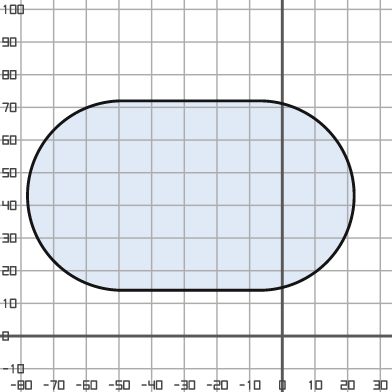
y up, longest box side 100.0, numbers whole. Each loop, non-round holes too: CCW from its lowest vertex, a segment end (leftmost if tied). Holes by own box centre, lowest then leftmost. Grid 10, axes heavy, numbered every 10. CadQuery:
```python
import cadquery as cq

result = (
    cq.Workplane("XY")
    .moveTo(-49.0, 14.0)
    .lineTo(-7.0, 14.0)
    .threePointArc((22.0, 43.0), (-7.0, 72.0))
    .lineTo(-49.0, 72.0)
    .threePointArc((-78.0, 43.0), (-49.0, 14.0))
    .close()
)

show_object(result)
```